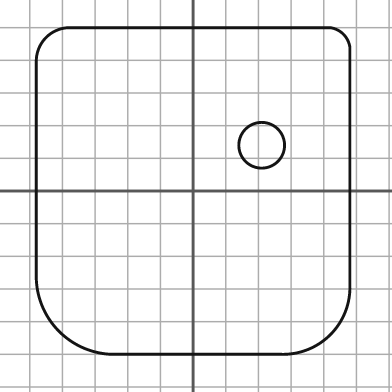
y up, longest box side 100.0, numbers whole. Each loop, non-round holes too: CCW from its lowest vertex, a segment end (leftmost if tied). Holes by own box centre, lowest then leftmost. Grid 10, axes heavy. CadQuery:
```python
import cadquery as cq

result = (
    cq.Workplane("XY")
    .moveTo(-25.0, -50.0)
    .lineTo(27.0, -50.0)
    .threePointArc((42.0, -44.0), (48.0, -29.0))
    .lineTo(48.0, 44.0)
    .threePointArc((46.0, 48.0), (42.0, 50.0))
    .lineTo(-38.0, 50.0)
    .threePointArc((-45.0, 47.0), (-48.0, 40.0))
    .lineTo(-48.0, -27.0)
    .threePointArc((-41.0, -43.0), (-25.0, -50.0))
    .close()
    .moveTo(21.0, 14.0)
    .circle(7.0)
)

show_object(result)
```